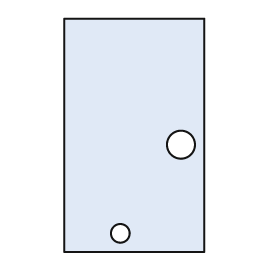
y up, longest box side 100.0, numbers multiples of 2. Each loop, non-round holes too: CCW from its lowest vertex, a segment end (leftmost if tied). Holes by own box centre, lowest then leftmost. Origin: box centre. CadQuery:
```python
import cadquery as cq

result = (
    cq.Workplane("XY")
    .moveTo(-30.0, -50.0)
    .lineTo(30.0, -50.0)
    .lineTo(30.0, 50.0)
    .lineTo(-30.0, 50.0)
    .close()
    .moveTo(-6.0, -42.0)
    .circle(4.0)
    .moveTo(20.0, -4.0)
    .circle(6.0)
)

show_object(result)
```